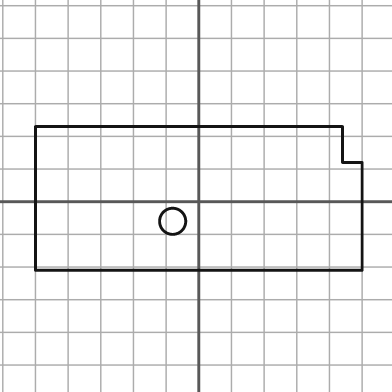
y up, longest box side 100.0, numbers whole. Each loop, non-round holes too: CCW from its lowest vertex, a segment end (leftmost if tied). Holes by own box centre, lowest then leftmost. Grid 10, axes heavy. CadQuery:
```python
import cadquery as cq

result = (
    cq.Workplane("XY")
    .moveTo(-50.0, -21.0)
    .lineTo(50.0, -21.0)
    .lineTo(50.0, 12.0)
    .lineTo(44.0, 12.0)
    .lineTo(44.0, 23.0)
    .lineTo(-50.0, 23.0)
    .close()
    .moveTo(-8.0, -6.0)
    .circle(4.0)
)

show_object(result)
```